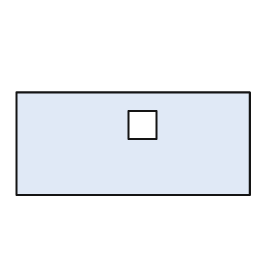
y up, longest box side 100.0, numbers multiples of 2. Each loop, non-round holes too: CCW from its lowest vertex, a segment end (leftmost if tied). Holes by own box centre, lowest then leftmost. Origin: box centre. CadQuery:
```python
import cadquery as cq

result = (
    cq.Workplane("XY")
    .moveTo(-50.0, -22.0)
    .lineTo(50.0, -22.0)
    .lineTo(50.0, 22.0)
    .lineTo(-50.0, 22.0)
    .close()
    .moveTo(-2.0, 2.0)
    .lineTo(10.0, 2.0)
    .lineTo(10.0, 14.0)
    .lineTo(-2.0, 14.0)
    .close()
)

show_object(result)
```